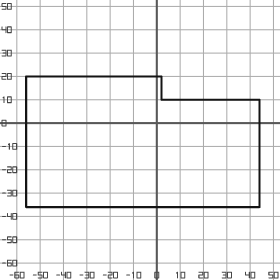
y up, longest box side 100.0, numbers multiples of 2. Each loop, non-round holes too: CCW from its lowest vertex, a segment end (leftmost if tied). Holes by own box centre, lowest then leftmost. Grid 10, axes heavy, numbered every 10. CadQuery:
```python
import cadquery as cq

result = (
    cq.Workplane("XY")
    .moveTo(-56.0, -36.0)
    .lineTo(44.0, -36.0)
    .lineTo(44.0, 10.0)
    .lineTo(2.0, 10.0)
    .lineTo(2.0, 20.0)
    .lineTo(-56.0, 20.0)
    .close()
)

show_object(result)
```